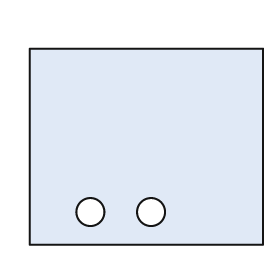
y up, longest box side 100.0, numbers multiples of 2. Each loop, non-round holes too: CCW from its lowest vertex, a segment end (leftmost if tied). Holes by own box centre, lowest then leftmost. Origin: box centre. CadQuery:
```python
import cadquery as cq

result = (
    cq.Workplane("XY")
    .moveTo(-50.0, -42.0)
    .lineTo(50.0, -42.0)
    .lineTo(50.0, 42.0)
    .lineTo(-50.0, 42.0)
    .close()
    .moveTo(-24.0, -28.0)
    .circle(6.0)
    .moveTo(2.0, -28.0)
    .circle(6.0)
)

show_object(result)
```